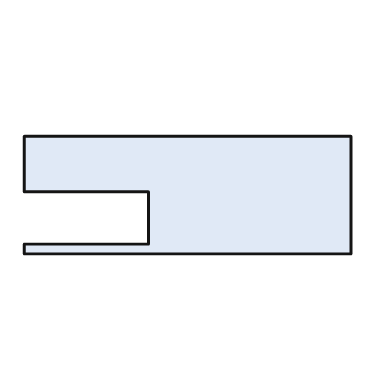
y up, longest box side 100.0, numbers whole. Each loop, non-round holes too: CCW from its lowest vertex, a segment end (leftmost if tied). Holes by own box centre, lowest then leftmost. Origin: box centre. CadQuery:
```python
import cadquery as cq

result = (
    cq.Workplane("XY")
    .moveTo(-50.0, -18.0)
    .lineTo(50.0, -18.0)
    .lineTo(50.0, 18.0)
    .lineTo(-50.0, 18.0)
    .lineTo(-50.0, 1.0)
    .lineTo(-12.0, 1.0)
    .lineTo(-12.0, -15.0)
    .lineTo(-50.0, -15.0)
    .close()
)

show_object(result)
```